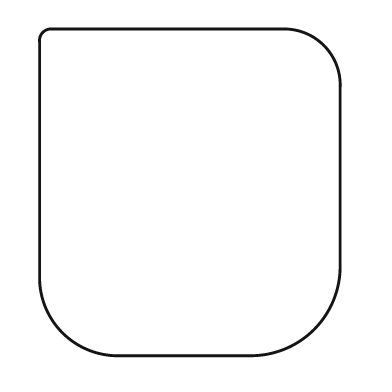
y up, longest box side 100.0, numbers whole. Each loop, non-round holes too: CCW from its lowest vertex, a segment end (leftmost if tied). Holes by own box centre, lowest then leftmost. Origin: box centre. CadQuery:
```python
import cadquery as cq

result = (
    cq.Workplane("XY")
    .moveTo(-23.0, -50.0)
    .lineTo(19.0, -50.0)
    .threePointArc((38.0, -42.0), (46.0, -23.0))
    .lineTo(46.0, 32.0)
    .threePointArc((41.0, 45.0), (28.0, 50.0))
    .lineTo(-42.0, 50.0)
    .threePointArc((-45.0, 49.0), (-46.0, 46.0))
    .lineTo(-46.0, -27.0)
    .threePointArc((-39.0, -43.0), (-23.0, -50.0))
    .close()
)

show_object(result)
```